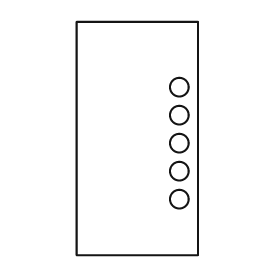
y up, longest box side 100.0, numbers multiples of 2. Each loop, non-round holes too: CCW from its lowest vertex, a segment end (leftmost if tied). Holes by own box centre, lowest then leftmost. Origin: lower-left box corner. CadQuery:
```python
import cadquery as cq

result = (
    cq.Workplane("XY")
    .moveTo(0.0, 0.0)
    .lineTo(52.0, 0.0)
    .lineTo(52.0, 100.0)
    .lineTo(0.0, 100.0)
    .close()
    .moveTo(44.0, 24.0)
    .circle(4.0)
    .moveTo(44.0, 36.0)
    .circle(4.0)
    .moveTo(44.0, 48.0)
    .circle(4.0)
    .moveTo(44.0, 60.0)
    .circle(4.0)
    .moveTo(44.0, 72.0)
    .circle(4.0)
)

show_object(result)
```